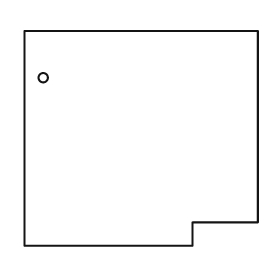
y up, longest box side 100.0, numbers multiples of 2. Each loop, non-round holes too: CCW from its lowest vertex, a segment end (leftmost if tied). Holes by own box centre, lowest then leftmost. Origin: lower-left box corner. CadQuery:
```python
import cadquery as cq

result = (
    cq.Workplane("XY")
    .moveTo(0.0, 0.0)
    .lineTo(72.0, 0.0)
    .lineTo(72.0, 10.0)
    .lineTo(100.0, 10.0)
    .lineTo(100.0, 92.0)
    .lineTo(0.0, 92.0)
    .close()
    .moveTo(8.0, 72.0)
    .circle(2.0)
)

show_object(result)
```